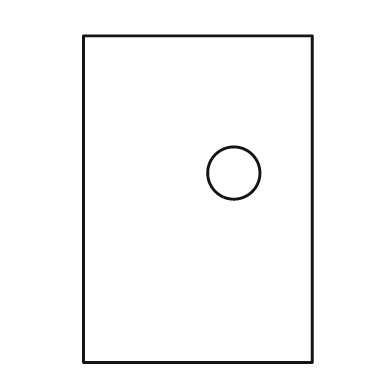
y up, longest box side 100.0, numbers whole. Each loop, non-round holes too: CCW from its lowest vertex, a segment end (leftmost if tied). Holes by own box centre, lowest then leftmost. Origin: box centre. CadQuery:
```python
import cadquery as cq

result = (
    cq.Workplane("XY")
    .moveTo(-35.0, -50.0)
    .lineTo(35.0, -50.0)
    .lineTo(35.0, 50.0)
    .lineTo(-35.0, 50.0)
    .close()
    .moveTo(11.0, 8.0)
    .circle(8.0)
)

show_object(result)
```